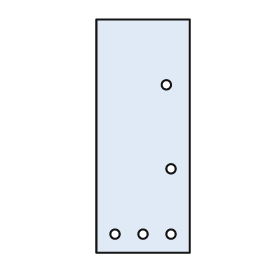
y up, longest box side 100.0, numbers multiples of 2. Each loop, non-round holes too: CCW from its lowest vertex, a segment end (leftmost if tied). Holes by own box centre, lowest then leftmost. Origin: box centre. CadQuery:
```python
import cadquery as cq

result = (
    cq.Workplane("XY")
    .moveTo(-20.0, -50.0)
    .lineTo(20.0, -50.0)
    .lineTo(20.0, 50.0)
    .lineTo(-20.0, 50.0)
    .close()
    .moveTo(-12.0, -42.0)
    .circle(2.0)
    .moveTo(0.0, -42.0)
    .circle(2.0)
    .moveTo(12.0, -42.0)
    .circle(2.0)
    .moveTo(12.0, -14.0)
    .circle(2.0)
    .moveTo(10.0, 22.0)
    .circle(2.0)
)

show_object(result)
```